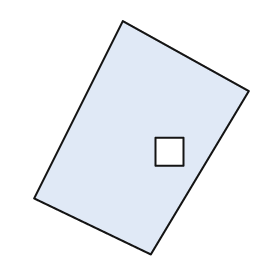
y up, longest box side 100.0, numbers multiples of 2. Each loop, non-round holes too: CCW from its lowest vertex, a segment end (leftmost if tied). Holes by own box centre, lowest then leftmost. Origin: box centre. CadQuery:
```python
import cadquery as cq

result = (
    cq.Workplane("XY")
    .moveTo(4.0, -50.0)
    .lineTo(46.0, 20.0)
    .lineTo(-8.0, 50.0)
    .lineTo(-46.0, -26.0)
    .close()
    .moveTo(6.0, -12.0)
    .lineTo(18.0, -12.0)
    .lineTo(18.0, 0.0)
    .lineTo(6.0, 0.0)
    .close()
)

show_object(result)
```